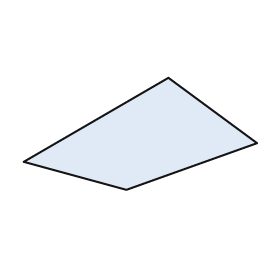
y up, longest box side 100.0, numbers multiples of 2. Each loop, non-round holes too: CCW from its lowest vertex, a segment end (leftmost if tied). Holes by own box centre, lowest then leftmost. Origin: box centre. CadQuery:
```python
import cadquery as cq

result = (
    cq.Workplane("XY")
    .moveTo(-6.0, -24.0)
    .lineTo(50.0, -4.0)
    .lineTo(12.0, 24.0)
    .lineTo(-50.0, -12.0)
    .close()
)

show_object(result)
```